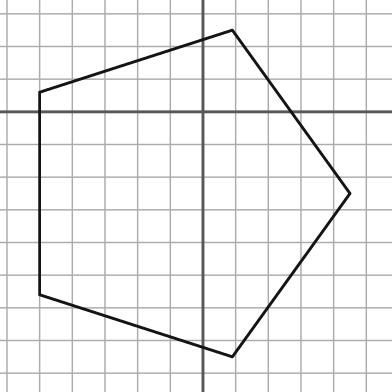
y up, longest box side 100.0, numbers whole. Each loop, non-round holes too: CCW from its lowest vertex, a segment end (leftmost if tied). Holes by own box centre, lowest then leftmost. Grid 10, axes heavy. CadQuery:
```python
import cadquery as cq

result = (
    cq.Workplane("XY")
    .moveTo(9.0, -75.0)
    .lineTo(45.0, -25.0)
    .lineTo(9.0, 25.0)
    .lineTo(-50.0, 6.0)
    .lineTo(-50.0, -56.0)
    .close()
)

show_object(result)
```